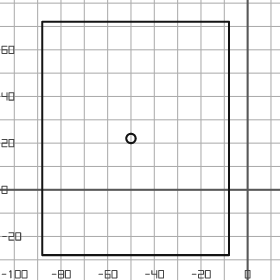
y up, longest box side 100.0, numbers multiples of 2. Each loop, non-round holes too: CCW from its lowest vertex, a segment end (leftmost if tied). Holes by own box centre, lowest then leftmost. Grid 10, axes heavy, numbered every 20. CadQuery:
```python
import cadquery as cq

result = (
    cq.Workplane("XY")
    .moveTo(-88.0, -28.0)
    .lineTo(-8.0, -28.0)
    .lineTo(-8.0, 72.0)
    .lineTo(-88.0, 72.0)
    .close()
    .moveTo(-50.0, 22.0)
    .circle(2.0)
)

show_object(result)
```